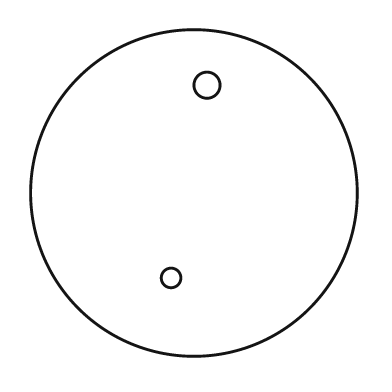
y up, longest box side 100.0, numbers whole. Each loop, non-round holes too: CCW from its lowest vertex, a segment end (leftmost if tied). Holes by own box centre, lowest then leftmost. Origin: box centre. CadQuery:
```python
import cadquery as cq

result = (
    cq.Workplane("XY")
    .moveTo(0.0, 0.0)
    .circle(50.0)
    .moveTo(-7.0, -26.0)
    .circle(3.0)
    .moveTo(4.0, 33.0)
    .circle(4.0)
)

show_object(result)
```